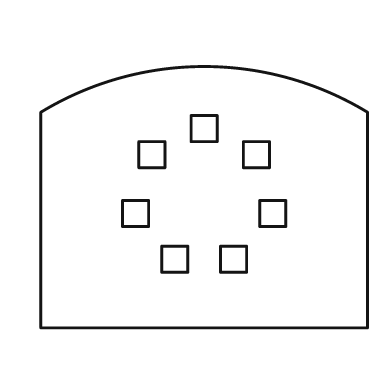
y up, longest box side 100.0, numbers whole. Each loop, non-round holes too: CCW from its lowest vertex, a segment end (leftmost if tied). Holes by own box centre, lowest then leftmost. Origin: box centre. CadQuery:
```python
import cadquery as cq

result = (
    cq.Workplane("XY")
    .moveTo(-50.0, -40.0)
    .lineTo(50.0, -40.0)
    .lineTo(50.0, 26.0)
    .threePointArc((0.0, 40.0), (-50.0, 26.0))
    .close()
    .moveTo(-13.0, -23.0)
    .lineTo(-5.0, -23.0)
    .lineTo(-5.0, -15.0)
    .lineTo(-13.0, -15.0)
    .close()
    .moveTo(5.0, -23.0)
    .lineTo(13.0, -23.0)
    .lineTo(13.0, -15.0)
    .lineTo(5.0, -15.0)
    .close()
    .moveTo(-25.0, -9.0)
    .lineTo(-17.0, -9.0)
    .lineTo(-17.0, -1.0)
    .lineTo(-25.0, -1.0)
    .close()
    .moveTo(17.0, -9.0)
    .lineTo(25.0, -9.0)
    .lineTo(25.0, -1.0)
    .lineTo(17.0, -1.0)
    .close()
    .moveTo(-20.0, 9.0)
    .lineTo(-12.0, 9.0)
    .lineTo(-12.0, 17.0)
    .lineTo(-20.0, 17.0)
    .close()
    .moveTo(12.0, 9.0)
    .lineTo(20.0, 9.0)
    .lineTo(20.0, 17.0)
    .lineTo(12.0, 17.0)
    .close()
    .moveTo(-4.0, 17.0)
    .lineTo(4.0, 17.0)
    .lineTo(4.0, 25.0)
    .lineTo(-4.0, 25.0)
    .close()
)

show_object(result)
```